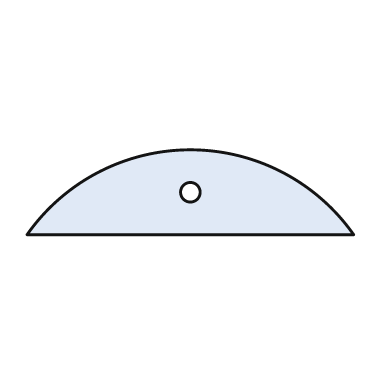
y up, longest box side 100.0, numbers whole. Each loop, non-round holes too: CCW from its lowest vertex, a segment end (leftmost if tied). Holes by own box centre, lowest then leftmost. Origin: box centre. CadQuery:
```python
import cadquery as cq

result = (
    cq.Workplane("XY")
    .moveTo(-50.0, -13.0)
    .lineTo(50.0, -13.0)
    .threePointArc((0.0, 13.0), (-50.0, -13.0))
    .close()
    .moveTo(0.0, 0.0)
    .circle(3.0)
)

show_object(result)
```